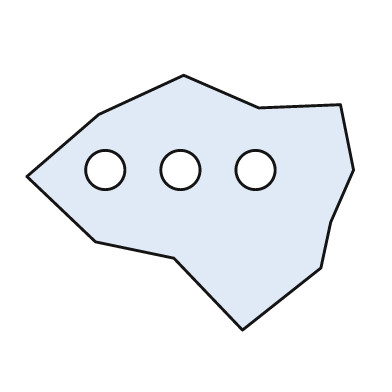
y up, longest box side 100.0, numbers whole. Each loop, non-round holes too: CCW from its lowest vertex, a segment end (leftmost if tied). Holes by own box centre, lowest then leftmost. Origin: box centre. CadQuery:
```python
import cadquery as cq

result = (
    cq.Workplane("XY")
    .moveTo(16.0, -39.0)
    .lineTo(40.0, -20.0)
    .lineTo(43.0, -6.0)
    .lineTo(50.0, 10.0)
    .lineTo(46.0, 30.0)
    .lineTo(21.0, 29.0)
    .lineTo(-2.0, 39.0)
    .lineTo(-28.0, 27.0)
    .lineTo(-50.0, 8.0)
    .lineTo(-29.0, -12.0)
    .lineTo(-5.0, -17.0)
    .close()
    .moveTo(-26.0, 10.0)
    .circle(6.0)
    .moveTo(-3.0, 10.0)
    .circle(6.0)
    .moveTo(20.0, 10.0)
    .circle(6.0)
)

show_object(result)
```